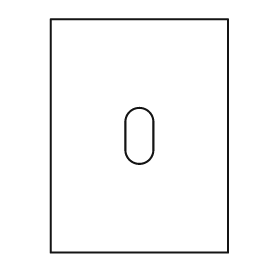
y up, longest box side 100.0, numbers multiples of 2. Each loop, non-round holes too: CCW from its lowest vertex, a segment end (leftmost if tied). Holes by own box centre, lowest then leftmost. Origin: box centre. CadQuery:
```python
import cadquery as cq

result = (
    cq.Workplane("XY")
    .moveTo(-38.0, -50.0)
    .lineTo(38.0, -50.0)
    .lineTo(38.0, 50.0)
    .lineTo(-38.0, 50.0)
    .close()
    .moveTo(-6.0, -6.0)
    .threePointArc((0.0, -12.0), (6.0, -6.0))
    .lineTo(6.0, 6.0)
    .threePointArc((0.0, 12.0), (-6.0, 6.0))
    .close()
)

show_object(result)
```